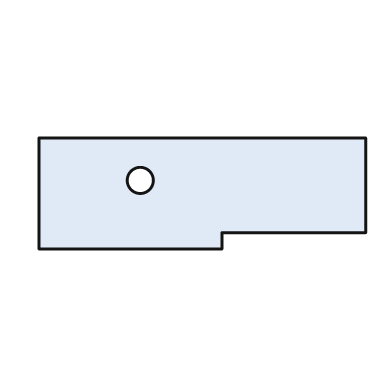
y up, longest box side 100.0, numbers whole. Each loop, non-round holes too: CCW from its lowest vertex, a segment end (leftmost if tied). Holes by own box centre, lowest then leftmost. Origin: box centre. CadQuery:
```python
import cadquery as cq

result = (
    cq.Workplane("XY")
    .moveTo(-50.0, -17.0)
    .lineTo(6.0, -17.0)
    .lineTo(6.0, -12.0)
    .lineTo(50.0, -12.0)
    .lineTo(50.0, 17.0)
    .lineTo(-50.0, 17.0)
    .close()
    .moveTo(-19.0, 4.0)
    .circle(4.0)
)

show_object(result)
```